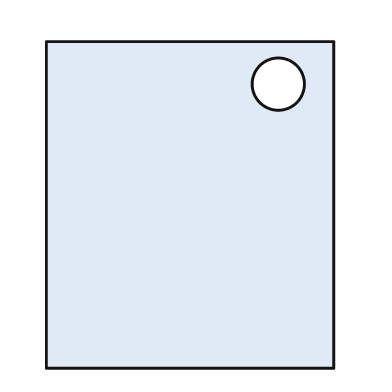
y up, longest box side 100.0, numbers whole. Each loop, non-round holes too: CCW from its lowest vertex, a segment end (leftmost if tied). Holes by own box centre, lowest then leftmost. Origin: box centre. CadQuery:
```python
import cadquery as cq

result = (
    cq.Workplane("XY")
    .moveTo(-44.0, -50.0)
    .lineTo(44.0, -50.0)
    .lineTo(44.0, 50.0)
    .lineTo(-44.0, 50.0)
    .close()
    .moveTo(27.0, 37.0)
    .circle(8.0)
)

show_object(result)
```